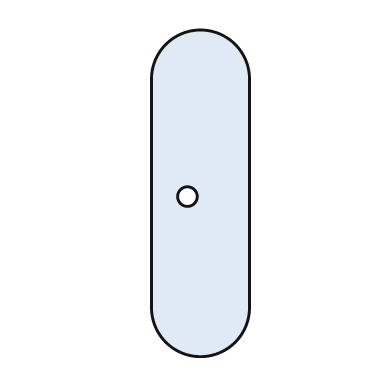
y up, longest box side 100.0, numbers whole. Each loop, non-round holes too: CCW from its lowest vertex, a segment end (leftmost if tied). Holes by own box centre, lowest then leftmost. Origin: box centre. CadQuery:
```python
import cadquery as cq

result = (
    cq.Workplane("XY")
    .moveTo(-15.0, -35.0)
    .threePointArc((0.0, -50.0), (15.0, -35.0))
    .lineTo(15.0, 35.0)
    .threePointArc((0.0, 50.0), (-15.0, 35.0))
    .close()
    .moveTo(-4.0, -1.0)
    .circle(3.0)
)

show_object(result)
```